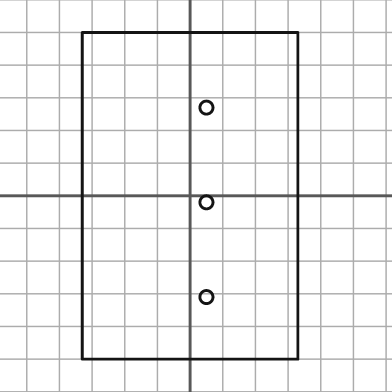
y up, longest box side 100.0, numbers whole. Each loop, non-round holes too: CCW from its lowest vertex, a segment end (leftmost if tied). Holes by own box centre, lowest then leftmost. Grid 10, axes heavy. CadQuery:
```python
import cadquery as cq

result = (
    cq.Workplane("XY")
    .moveTo(-33.0, -50.0)
    .lineTo(33.0, -50.0)
    .lineTo(33.0, 50.0)
    .lineTo(-33.0, 50.0)
    .close()
    .moveTo(5.0, -31.0)
    .circle(2.0)
    .moveTo(5.0, -2.0)
    .circle(2.0)
    .moveTo(5.0, 27.0)
    .circle(2.0)
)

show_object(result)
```